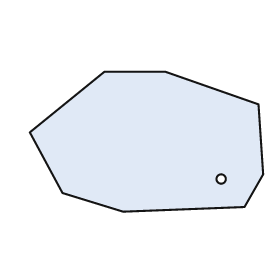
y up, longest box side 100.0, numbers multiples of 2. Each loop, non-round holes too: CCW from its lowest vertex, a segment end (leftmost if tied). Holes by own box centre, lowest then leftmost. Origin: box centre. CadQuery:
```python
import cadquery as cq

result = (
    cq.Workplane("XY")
    .moveTo(-10.0, -30.0)
    .lineTo(42.0, -28.0)
    .lineTo(50.0, -14.0)
    .lineTo(48.0, 16.0)
    .lineTo(8.0, 30.0)
    .lineTo(-18.0, 30.0)
    .lineTo(-50.0, 4.0)
    .lineTo(-36.0, -22.0)
    .close()
    .moveTo(32.0, -16.0)
    .circle(2.0)
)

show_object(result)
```